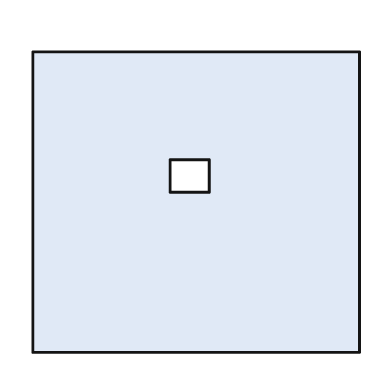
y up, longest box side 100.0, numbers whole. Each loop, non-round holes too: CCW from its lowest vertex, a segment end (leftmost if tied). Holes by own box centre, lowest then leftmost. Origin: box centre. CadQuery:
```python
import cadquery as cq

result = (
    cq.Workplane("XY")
    .moveTo(-50.0, -46.0)
    .lineTo(50.0, -46.0)
    .lineTo(50.0, 46.0)
    .lineTo(-50.0, 46.0)
    .close()
    .moveTo(-8.0, 3.0)
    .lineTo(4.0, 3.0)
    .lineTo(4.0, 13.0)
    .lineTo(-8.0, 13.0)
    .close()
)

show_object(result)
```